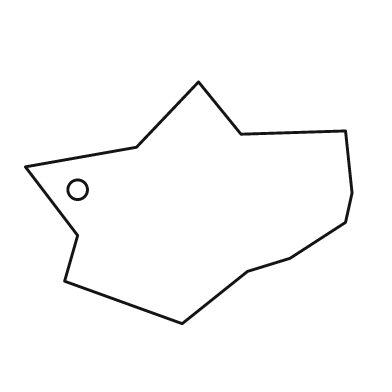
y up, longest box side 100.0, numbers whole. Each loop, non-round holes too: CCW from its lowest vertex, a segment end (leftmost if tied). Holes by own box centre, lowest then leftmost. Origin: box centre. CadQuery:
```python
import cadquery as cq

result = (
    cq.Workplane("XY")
    .moveTo(-2.0, -37.0)
    .lineTo(18.0, -21.0)
    .lineTo(31.0, -17.0)
    .lineTo(48.0, -6.0)
    .lineTo(50.0, 3.0)
    .lineTo(48.0, 22.0)
    .lineTo(16.0, 21.0)
    .lineTo(3.0, 37.0)
    .lineTo(-16.0, 17.0)
    .lineTo(-50.0, 11.0)
    .lineTo(-34.0, -10.0)
    .lineTo(-38.0, -24.0)
    .close()
    .moveTo(-34.0, 4.0)
    .circle(3.0)
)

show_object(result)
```